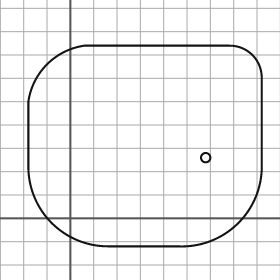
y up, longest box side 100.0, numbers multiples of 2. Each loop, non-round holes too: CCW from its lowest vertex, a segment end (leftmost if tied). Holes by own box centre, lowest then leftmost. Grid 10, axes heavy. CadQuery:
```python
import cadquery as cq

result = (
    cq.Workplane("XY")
    .moveTo(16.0, -12.0)
    .lineTo(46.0, -12.0)
    .threePointArc((72.0, -2.0), (82.0, 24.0))
    .lineTo(82.0, 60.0)
    .threePointArc((78.0, 70.0), (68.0, 74.0))
    .lineTo(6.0, 74.0)
    .threePointArc((-10.0, 66.0), (-18.0, 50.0))
    .lineTo(-18.0, 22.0)
    .threePointArc((-8.0, -2.0), (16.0, -12.0))
    .close()
    .moveTo(58.0, 26.0)
    .circle(2.0)
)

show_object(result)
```